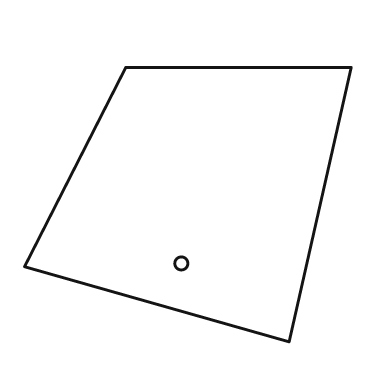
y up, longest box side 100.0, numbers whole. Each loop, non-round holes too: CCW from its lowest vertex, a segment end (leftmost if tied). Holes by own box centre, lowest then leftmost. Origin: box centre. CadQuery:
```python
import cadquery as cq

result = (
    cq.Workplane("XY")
    .moveTo(31.0, -42.0)
    .lineTo(50.0, 42.0)
    .lineTo(-19.0, 42.0)
    .lineTo(-50.0, -19.0)
    .close()
    .moveTo(-2.0, -18.0)
    .circle(2.0)
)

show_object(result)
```